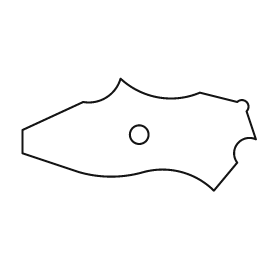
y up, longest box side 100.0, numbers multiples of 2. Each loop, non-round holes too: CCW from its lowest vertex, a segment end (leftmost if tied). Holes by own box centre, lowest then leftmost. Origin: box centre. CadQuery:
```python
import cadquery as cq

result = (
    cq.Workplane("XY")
    .moveTo(32.0, -24.0)
    .lineTo(42.0, -12.0)
    .threePointArc((42.0, -4.0), (50.0, -2.0))
    .lineTo(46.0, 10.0)
    .threePointArc((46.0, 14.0), (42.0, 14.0))
    .lineTo(26.0, 18.0)
    .threePointArc((8.0, 16.0), (-8.0, 24.0))
    .threePointArc((-14.0, 16.0), (-24.0, 14.0))
    .lineTo(-50.0, 2.0)
    .lineTo(-50.0, -8.0)
    .lineTo(-26.0, -16.0)
    .threePointArc((-12.0, -18.0), (2.0, -16.0))
    .threePointArc((18.0, -16.0), (32.0, -24.0))
    .close()
    .moveTo(0.0, 0.0)
    .circle(4.0)
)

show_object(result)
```